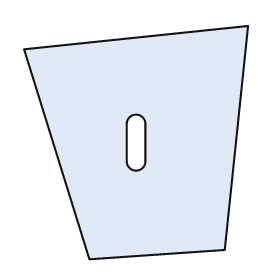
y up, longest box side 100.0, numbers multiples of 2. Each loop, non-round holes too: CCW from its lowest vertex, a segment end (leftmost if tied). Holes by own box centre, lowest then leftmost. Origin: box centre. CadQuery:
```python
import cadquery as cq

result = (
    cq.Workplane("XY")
    .moveTo(-20.0, -50.0)
    .lineTo(38.0, -46.0)
    .lineTo(48.0, 50.0)
    .lineTo(-48.0, 40.0)
    .close()
    .moveTo(-4.0, -8.0)
    .threePointArc((0.0, -12.0), (4.0, -8.0))
    .lineTo(4.0, 8.0)
    .threePointArc((0.0, 12.0), (-4.0, 8.0))
    .close()
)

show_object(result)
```